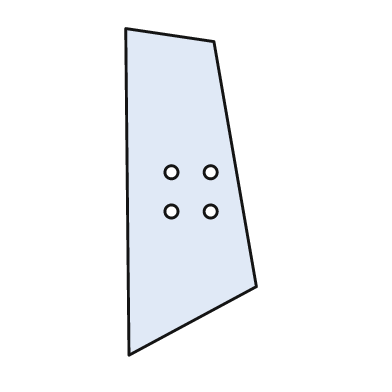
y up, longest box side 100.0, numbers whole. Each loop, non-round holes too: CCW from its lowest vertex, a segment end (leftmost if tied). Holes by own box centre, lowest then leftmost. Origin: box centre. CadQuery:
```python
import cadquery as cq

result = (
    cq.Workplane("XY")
    .moveTo(-19.0, -50.0)
    .lineTo(20.0, -29.0)
    .lineTo(7.0, 46.0)
    .lineTo(-20.0, 50.0)
    .close()
    .moveTo(-6.0, -6.0)
    .circle(2.0)
    .moveTo(6.0, -6.0)
    .circle(2.0)
    .moveTo(-6.0, 6.0)
    .circle(2.0)
    .moveTo(6.0, 6.0)
    .circle(2.0)
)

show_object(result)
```